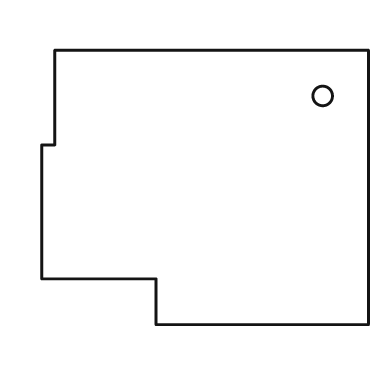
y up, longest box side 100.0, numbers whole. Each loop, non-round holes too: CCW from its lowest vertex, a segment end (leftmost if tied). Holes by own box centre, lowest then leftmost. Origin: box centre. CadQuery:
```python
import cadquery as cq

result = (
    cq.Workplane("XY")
    .moveTo(-15.0, -42.0)
    .lineTo(50.0, -42.0)
    .lineTo(50.0, 42.0)
    .lineTo(-46.0, 42.0)
    .lineTo(-46.0, 13.0)
    .lineTo(-50.0, 13.0)
    .lineTo(-50.0, -28.0)
    .lineTo(-15.0, -28.0)
    .close()
    .moveTo(36.0, 28.0)
    .circle(3.0)
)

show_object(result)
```